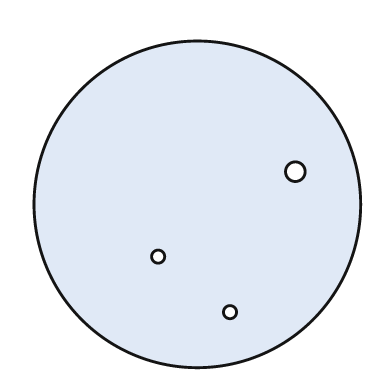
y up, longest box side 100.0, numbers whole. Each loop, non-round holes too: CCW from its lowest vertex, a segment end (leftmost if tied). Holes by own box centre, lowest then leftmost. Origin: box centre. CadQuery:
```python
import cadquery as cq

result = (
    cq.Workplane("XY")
    .moveTo(0.0, 0.0)
    .circle(50.0)
    .moveTo(10.0, -33.0)
    .circle(2.0)
    .moveTo(-12.0, -16.0)
    .circle(2.0)
    .moveTo(30.0, 10.0)
    .circle(3.0)
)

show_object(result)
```